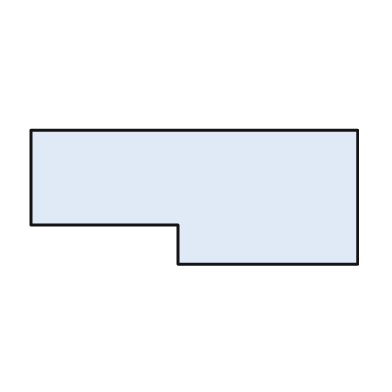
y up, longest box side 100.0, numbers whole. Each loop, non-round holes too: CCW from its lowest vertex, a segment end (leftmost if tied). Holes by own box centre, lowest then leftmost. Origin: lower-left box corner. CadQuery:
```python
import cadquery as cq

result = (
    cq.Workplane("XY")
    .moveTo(45.0, 0.0)
    .lineTo(100.0, 0.0)
    .lineTo(100.0, 41.0)
    .lineTo(0.0, 41.0)
    .lineTo(0.0, 12.0)
    .lineTo(45.0, 12.0)
    .close()
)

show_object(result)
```